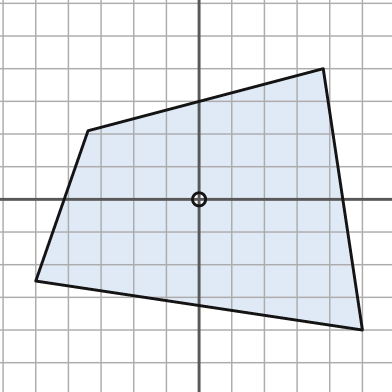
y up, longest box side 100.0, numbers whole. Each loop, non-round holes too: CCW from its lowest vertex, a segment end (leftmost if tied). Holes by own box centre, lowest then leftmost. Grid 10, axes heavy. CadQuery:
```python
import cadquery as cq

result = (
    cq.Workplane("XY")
    .moveTo(50.0, -40.0)
    .lineTo(38.0, 40.0)
    .lineTo(-34.0, 21.0)
    .lineTo(-50.0, -25.0)
    .close()
    .moveTo(0.0, 0.0)
    .circle(2.0)
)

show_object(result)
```